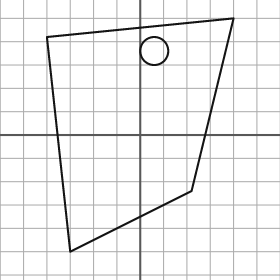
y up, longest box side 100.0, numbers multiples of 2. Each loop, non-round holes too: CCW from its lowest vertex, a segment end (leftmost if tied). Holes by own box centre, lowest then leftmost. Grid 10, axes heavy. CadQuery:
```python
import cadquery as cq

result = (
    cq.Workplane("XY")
    .moveTo(-30.0, -50.0)
    .lineTo(22.0, -24.0)
    .lineTo(40.0, 50.0)
    .lineTo(-40.0, 42.0)
    .close()
    .moveTo(6.0, 36.0)
    .circle(6.0)
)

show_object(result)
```